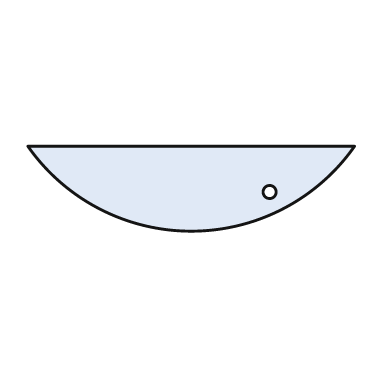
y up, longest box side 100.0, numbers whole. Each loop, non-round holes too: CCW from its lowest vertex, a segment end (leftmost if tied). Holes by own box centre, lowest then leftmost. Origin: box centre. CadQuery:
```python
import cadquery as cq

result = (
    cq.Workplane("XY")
    .moveTo(-50.0, 13.0)
    .threePointArc((0.0, -13.0), (50.0, 13.0))
    .close()
    .moveTo(24.0, -1.0)
    .circle(2.0)
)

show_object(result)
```